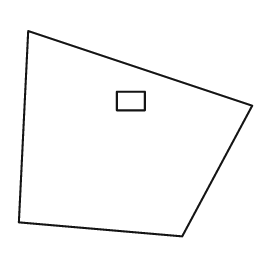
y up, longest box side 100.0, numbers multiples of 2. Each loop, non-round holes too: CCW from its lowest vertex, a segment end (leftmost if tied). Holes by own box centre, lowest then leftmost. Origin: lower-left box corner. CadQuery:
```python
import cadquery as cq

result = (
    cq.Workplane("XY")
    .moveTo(70.0, 0.0)
    .lineTo(100.0, 56.0)
    .lineTo(4.0, 88.0)
    .lineTo(0.0, 6.0)
    .close()
    .moveTo(42.0, 54.0)
    .lineTo(54.0, 54.0)
    .lineTo(54.0, 62.0)
    .lineTo(42.0, 62.0)
    .close()
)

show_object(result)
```